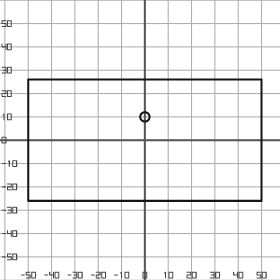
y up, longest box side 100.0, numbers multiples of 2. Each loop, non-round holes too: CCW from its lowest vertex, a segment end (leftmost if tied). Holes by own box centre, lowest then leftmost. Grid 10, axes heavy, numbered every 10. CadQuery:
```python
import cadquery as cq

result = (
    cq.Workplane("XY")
    .moveTo(-50.0, -26.0)
    .lineTo(50.0, -26.0)
    .lineTo(50.0, 26.0)
    .lineTo(-50.0, 26.0)
    .close()
    .moveTo(0.0, 10.0)
    .circle(2.0)
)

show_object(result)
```